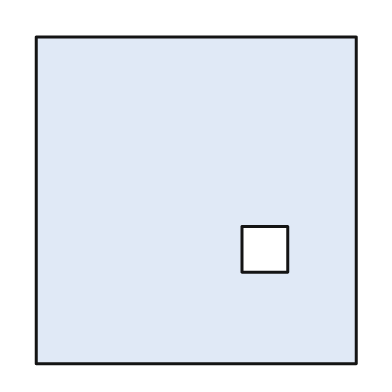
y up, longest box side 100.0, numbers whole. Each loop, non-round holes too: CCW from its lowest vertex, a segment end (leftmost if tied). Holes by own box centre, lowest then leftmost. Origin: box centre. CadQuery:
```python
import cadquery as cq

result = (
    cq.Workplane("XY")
    .moveTo(-49.0, -50.0)
    .lineTo(49.0, -50.0)
    .lineTo(49.0, 50.0)
    .lineTo(-49.0, 50.0)
    .close()
    .moveTo(14.0, -22.0)
    .lineTo(28.0, -22.0)
    .lineTo(28.0, -8.0)
    .lineTo(14.0, -8.0)
    .close()
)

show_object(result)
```